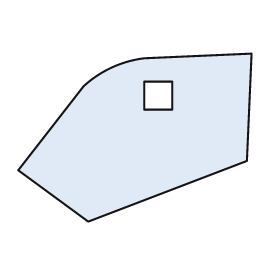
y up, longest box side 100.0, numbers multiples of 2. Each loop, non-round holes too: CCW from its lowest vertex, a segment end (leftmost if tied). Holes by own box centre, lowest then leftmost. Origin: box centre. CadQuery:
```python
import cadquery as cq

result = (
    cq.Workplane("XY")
    .moveTo(-20.0, -36.0)
    .lineTo(48.0, -10.0)
    .lineTo(50.0, 36.0)
    .lineTo(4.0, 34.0)
    .threePointArc((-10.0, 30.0), (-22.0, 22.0))
    .lineTo(-50.0, -14.0)
    .close()
    .moveTo(4.0, 12.0)
    .lineTo(16.0, 12.0)
    .lineTo(16.0, 24.0)
    .lineTo(4.0, 24.0)
    .close()
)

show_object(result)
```